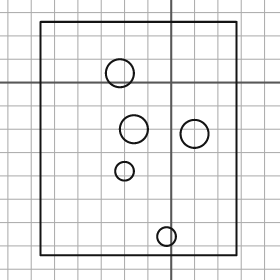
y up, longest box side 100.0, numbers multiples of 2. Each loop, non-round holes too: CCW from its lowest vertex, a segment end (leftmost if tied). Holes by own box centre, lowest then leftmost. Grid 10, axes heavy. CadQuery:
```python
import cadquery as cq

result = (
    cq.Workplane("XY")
    .moveTo(-56.0, -74.0)
    .lineTo(28.0, -74.0)
    .lineTo(28.0, 26.0)
    .lineTo(-56.0, 26.0)
    .close()
    .moveTo(-2.0, -66.0)
    .circle(4.0)
    .moveTo(-20.0, -38.0)
    .circle(4.0)
    .moveTo(10.0, -22.0)
    .circle(6.0)
    .moveTo(-16.0, -20.0)
    .circle(6.0)
    .moveTo(-22.0, 4.0)
    .circle(6.0)
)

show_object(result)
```